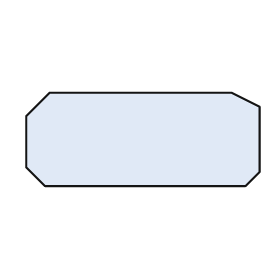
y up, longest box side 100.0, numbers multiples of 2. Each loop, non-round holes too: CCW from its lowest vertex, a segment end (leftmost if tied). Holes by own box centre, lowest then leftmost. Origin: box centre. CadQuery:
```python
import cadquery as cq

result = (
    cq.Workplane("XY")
    .moveTo(-42.0, -20.0)
    .lineTo(44.0, -20.0)
    .lineTo(50.0, -14.0)
    .lineTo(50.0, 14.0)
    .lineTo(38.0, 20.0)
    .lineTo(-40.0, 20.0)
    .lineTo(-50.0, 10.0)
    .lineTo(-50.0, -12.0)
    .close()
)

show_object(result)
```